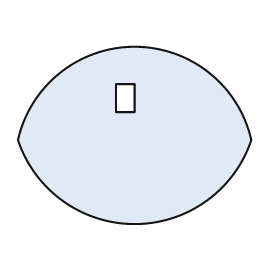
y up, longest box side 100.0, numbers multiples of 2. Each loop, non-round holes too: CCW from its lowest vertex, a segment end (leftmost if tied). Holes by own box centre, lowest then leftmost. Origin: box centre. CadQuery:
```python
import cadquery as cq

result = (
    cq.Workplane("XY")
    .moveTo(-50.0, -2.0)
    .threePointArc((0.0, -38.0), (50.0, -2.0))
    .threePointArc((0.0, 38.0), (-50.0, -2.0))
    .close()
    .moveTo(-8.0, 10.0)
    .lineTo(0.0, 10.0)
    .lineTo(0.0, 22.0)
    .lineTo(-8.0, 22.0)
    .close()
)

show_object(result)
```